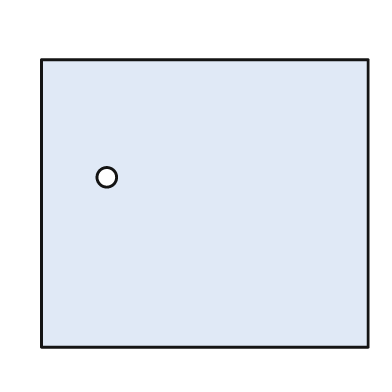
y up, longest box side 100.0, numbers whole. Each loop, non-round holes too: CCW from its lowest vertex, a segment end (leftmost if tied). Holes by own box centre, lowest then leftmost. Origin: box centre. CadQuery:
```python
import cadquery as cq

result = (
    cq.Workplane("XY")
    .moveTo(-50.0, -44.0)
    .lineTo(50.0, -44.0)
    .lineTo(50.0, 44.0)
    .lineTo(-50.0, 44.0)
    .close()
    .moveTo(-30.0, 8.0)
    .circle(3.0)
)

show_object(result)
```